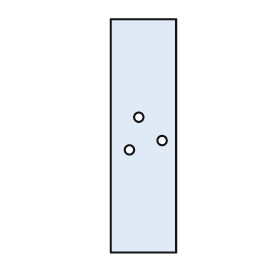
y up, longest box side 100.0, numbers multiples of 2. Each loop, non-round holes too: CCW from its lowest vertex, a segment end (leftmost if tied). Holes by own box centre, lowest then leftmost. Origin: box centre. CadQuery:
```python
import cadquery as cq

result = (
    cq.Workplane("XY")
    .moveTo(-14.0, -50.0)
    .lineTo(14.0, -50.0)
    .lineTo(14.0, 50.0)
    .lineTo(-14.0, 50.0)
    .close()
    .moveTo(-6.0, -6.0)
    .circle(2.0)
    .moveTo(8.0, -2.0)
    .circle(2.0)
    .moveTo(-2.0, 8.0)
    .circle(2.0)
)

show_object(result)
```